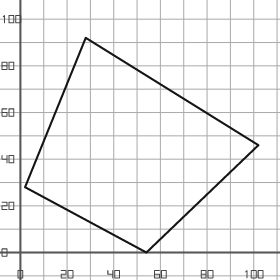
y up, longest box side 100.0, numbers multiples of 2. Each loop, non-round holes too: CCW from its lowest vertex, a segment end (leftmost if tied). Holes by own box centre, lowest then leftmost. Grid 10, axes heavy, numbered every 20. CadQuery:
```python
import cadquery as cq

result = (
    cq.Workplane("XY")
    .moveTo(54.0, 0.0)
    .lineTo(102.0, 46.0)
    .lineTo(28.0, 92.0)
    .lineTo(2.0, 28.0)
    .close()
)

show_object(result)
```